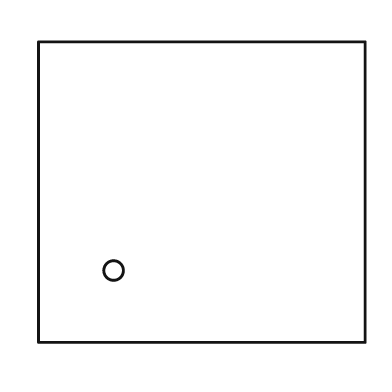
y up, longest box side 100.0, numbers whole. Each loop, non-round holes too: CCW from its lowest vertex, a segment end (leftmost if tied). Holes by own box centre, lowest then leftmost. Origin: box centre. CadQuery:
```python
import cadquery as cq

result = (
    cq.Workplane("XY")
    .moveTo(-50.0, -46.0)
    .lineTo(50.0, -46.0)
    .lineTo(50.0, 46.0)
    .lineTo(-50.0, 46.0)
    .close()
    .moveTo(-27.0, -24.0)
    .circle(3.0)
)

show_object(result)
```